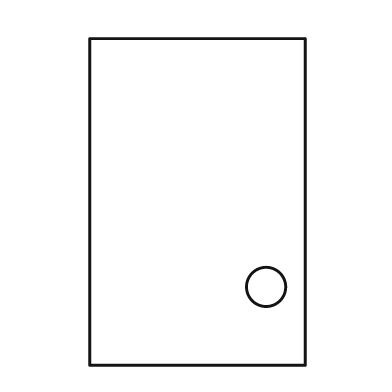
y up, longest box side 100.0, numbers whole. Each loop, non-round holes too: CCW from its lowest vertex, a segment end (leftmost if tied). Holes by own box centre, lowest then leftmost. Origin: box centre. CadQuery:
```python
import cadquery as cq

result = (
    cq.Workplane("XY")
    .moveTo(-33.0, -50.0)
    .lineTo(33.0, -50.0)
    .lineTo(33.0, 50.0)
    .lineTo(-33.0, 50.0)
    .close()
    .moveTo(21.0, -26.0)
    .circle(6.0)
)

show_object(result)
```